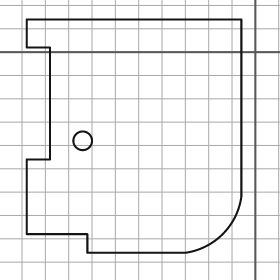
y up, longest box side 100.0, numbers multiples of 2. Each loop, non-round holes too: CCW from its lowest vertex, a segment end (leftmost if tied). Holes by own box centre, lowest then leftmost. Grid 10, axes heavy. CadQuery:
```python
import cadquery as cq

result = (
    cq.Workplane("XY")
    .moveTo(-72.0, -86.0)
    .lineTo(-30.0, -86.0)
    .threePointArc((-14.0, -78.0), (-6.0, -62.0))
    .lineTo(-6.0, 14.0)
    .lineTo(-98.0, 14.0)
    .lineTo(-98.0, 2.0)
    .lineTo(-88.0, 2.0)
    .lineTo(-88.0, -46.0)
    .lineTo(-98.0, -46.0)
    .lineTo(-98.0, -78.0)
    .lineTo(-72.0, -78.0)
    .close()
    .moveTo(-74.0, -38.0)
    .circle(4.0)
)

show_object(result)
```